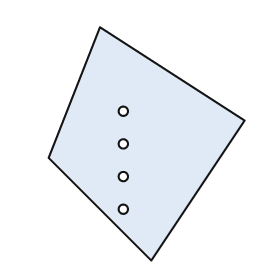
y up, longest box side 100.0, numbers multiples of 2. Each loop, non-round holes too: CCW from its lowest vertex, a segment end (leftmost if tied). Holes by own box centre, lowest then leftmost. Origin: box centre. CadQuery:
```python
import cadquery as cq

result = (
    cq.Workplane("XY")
    .moveTo(2.0, -50.0)
    .lineTo(42.0, 10.0)
    .lineTo(-20.0, 50.0)
    .lineTo(-42.0, -6.0)
    .close()
    .moveTo(-10.0, -28.0)
    .circle(2.0)
    .moveTo(-10.0, -14.0)
    .circle(2.0)
    .moveTo(-10.0, 0.0)
    .circle(2.0)
    .moveTo(-10.0, 14.0)
    .circle(2.0)
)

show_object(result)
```